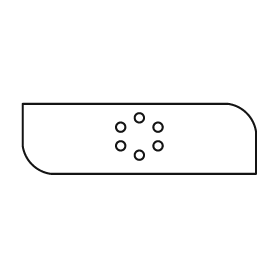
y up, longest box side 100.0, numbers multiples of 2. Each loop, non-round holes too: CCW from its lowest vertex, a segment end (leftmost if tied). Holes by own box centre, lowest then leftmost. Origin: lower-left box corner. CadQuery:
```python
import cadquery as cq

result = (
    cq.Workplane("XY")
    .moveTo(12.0, 0.0)
    .lineTo(100.0, 0.0)
    .lineTo(100.0, 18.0)
    .threePointArc((96.0, 26.0), (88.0, 30.0))
    .lineTo(0.0, 30.0)
    .lineTo(0.0, 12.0)
    .threePointArc((4.0, 4.0), (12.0, 0.0))
    .close()
    .moveTo(50.0, 8.0)
    .circle(2.0)
    .moveTo(42.0, 12.0)
    .circle(2.0)
    .moveTo(58.0, 12.0)
    .circle(2.0)
    .moveTo(42.0, 20.0)
    .circle(2.0)
    .moveTo(58.0, 20.0)
    .circle(2.0)
    .moveTo(50.0, 24.0)
    .circle(2.0)
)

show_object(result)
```